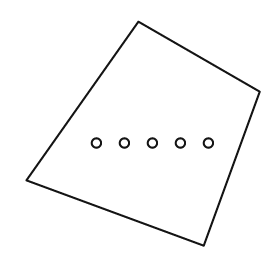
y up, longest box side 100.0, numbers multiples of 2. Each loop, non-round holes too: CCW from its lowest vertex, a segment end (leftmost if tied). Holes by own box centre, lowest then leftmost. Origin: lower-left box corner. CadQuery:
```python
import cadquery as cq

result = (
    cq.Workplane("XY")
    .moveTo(76.0, 0.0)
    .lineTo(100.0, 66.0)
    .lineTo(48.0, 96.0)
    .lineTo(0.0, 28.0)
    .close()
    .moveTo(30.0, 44.0)
    .circle(2.0)
    .moveTo(42.0, 44.0)
    .circle(2.0)
    .moveTo(54.0, 44.0)
    .circle(2.0)
    .moveTo(66.0, 44.0)
    .circle(2.0)
    .moveTo(78.0, 44.0)
    .circle(2.0)
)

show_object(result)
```